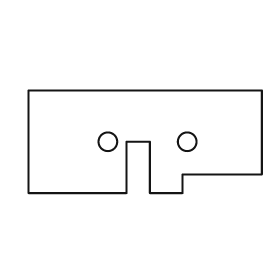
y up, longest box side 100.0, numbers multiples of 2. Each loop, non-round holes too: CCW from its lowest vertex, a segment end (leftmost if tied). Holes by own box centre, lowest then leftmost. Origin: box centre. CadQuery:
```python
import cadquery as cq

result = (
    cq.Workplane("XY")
    .moveTo(-50.0, -22.0)
    .lineTo(-8.0, -22.0)
    .lineTo(-8.0, 0.0)
    .lineTo(2.0, 0.0)
    .lineTo(2.0, -22.0)
    .lineTo(16.0, -22.0)
    .lineTo(16.0, -14.0)
    .lineTo(50.0, -14.0)
    .lineTo(50.0, 22.0)
    .lineTo(-50.0, 22.0)
    .close()
    .moveTo(-16.0, 0.0)
    .circle(4.0)
    .moveTo(18.0, 0.0)
    .circle(4.0)
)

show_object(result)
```